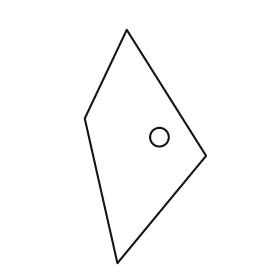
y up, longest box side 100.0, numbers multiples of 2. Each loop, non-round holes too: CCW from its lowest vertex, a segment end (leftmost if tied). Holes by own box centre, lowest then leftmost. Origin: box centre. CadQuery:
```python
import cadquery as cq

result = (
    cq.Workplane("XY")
    .moveTo(-12.0, -50.0)
    .lineTo(26.0, -4.0)
    .lineTo(-8.0, 50.0)
    .lineTo(-26.0, 12.0)
    .close()
    .moveTo(6.0, 4.0)
    .circle(4.0)
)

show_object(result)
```